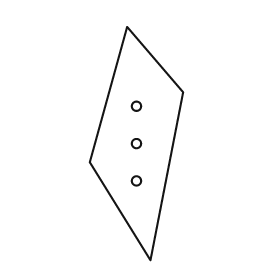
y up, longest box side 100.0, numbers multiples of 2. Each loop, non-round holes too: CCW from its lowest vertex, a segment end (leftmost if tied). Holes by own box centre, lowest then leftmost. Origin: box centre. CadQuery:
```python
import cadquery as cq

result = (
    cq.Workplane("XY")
    .moveTo(6.0, -50.0)
    .lineTo(20.0, 22.0)
    .lineTo(-4.0, 50.0)
    .lineTo(-20.0, -8.0)
    .close()
    .moveTo(0.0, -16.0)
    .circle(2.0)
    .moveTo(0.0, 0.0)
    .circle(2.0)
    .moveTo(0.0, 16.0)
    .circle(2.0)
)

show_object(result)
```